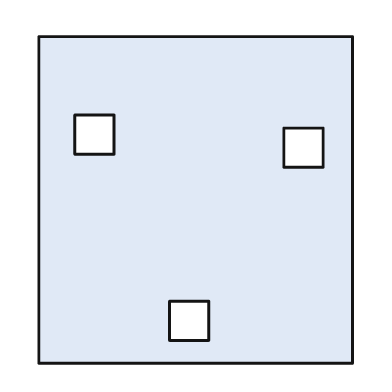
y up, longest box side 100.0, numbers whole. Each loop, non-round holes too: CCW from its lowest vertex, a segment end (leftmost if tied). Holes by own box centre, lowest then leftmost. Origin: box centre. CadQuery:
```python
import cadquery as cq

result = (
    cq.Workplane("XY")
    .moveTo(-48.0, -50.0)
    .lineTo(48.0, -50.0)
    .lineTo(48.0, 50.0)
    .lineTo(-48.0, 50.0)
    .close()
    .moveTo(-8.0, -43.0)
    .lineTo(4.0, -43.0)
    .lineTo(4.0, -31.0)
    .lineTo(-8.0, -31.0)
    .close()
    .moveTo(27.0, 10.0)
    .lineTo(39.0, 10.0)
    .lineTo(39.0, 22.0)
    .lineTo(27.0, 22.0)
    .close()
    .moveTo(-37.0, 14.0)
    .lineTo(-25.0, 14.0)
    .lineTo(-25.0, 26.0)
    .lineTo(-37.0, 26.0)
    .close()
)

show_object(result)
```